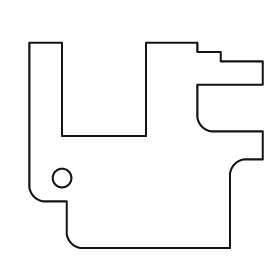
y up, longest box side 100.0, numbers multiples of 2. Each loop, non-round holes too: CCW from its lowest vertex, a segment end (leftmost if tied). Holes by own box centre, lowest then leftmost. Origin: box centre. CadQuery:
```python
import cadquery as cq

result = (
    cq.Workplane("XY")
    .moveTo(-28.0, -44.0)
    .lineTo(36.0, -44.0)
    .lineTo(36.0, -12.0)
    .threePointArc((38.0, -8.0), (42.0, -6.0))
    .lineTo(50.0, -6.0)
    .lineTo(50.0, 6.0)
    .lineTo(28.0, 6.0)
    .threePointArc((24.0, 8.0), (22.0, 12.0))
    .lineTo(22.0, 26.0)
    .lineTo(50.0, 26.0)
    .lineTo(50.0, 36.0)
    .lineTo(32.0, 36.0)
    .lineTo(32.0, 40.0)
    .lineTo(22.0, 40.0)
    .lineTo(22.0, 44.0)
    .lineTo(0.0, 44.0)
    .lineTo(0.0, 4.0)
    .lineTo(-36.0, 4.0)
    .lineTo(-36.0, 44.0)
    .lineTo(-50.0, 44.0)
    .lineTo(-50.0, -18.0)
    .threePointArc((-48.0, -22.0), (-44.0, -24.0))
    .lineTo(-34.0, -24.0)
    .lineTo(-34.0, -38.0)
    .threePointArc((-32.0, -42.0), (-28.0, -44.0))
    .close()
    .moveTo(-36.0, -14.0)
    .circle(4.0)
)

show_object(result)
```